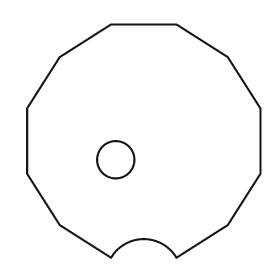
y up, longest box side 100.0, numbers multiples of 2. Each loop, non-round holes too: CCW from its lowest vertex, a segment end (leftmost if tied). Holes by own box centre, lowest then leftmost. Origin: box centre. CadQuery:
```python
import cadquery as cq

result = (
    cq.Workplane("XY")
    .moveTo(-14.0, -50.0)
    .threePointArc((0.0, -42.0), (14.0, -50.0))
    .lineTo(36.0, -36.0)
    .lineTo(50.0, -14.0)
    .lineTo(50.0, 14.0)
    .lineTo(36.0, 36.0)
    .lineTo(14.0, 50.0)
    .lineTo(-14.0, 50.0)
    .lineTo(-36.0, 36.0)
    .lineTo(-50.0, 14.0)
    .lineTo(-50.0, -14.0)
    .lineTo(-36.0, -36.0)
    .close()
    .moveTo(-12.0, -8.0)
    .circle(8.0)
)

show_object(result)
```